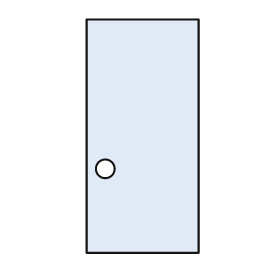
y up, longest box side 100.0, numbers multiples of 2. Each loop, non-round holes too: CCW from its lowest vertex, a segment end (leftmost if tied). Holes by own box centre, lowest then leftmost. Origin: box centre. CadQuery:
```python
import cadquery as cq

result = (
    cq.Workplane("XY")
    .moveTo(-24.0, -50.0)
    .lineTo(24.0, -50.0)
    .lineTo(24.0, 50.0)
    .lineTo(-24.0, 50.0)
    .close()
    .moveTo(-16.0, -14.0)
    .circle(4.0)
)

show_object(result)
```